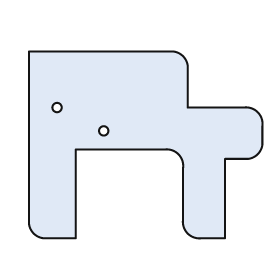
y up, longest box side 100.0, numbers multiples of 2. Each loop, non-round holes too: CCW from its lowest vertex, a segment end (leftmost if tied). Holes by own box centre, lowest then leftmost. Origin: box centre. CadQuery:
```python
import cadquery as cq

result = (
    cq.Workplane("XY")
    .moveTo(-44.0, -40.0)
    .lineTo(-30.0, -40.0)
    .lineTo(-30.0, -2.0)
    .lineTo(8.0, -2.0)
    .threePointArc((14.0, -4.0), (16.0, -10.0))
    .lineTo(16.0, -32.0)
    .threePointArc((18.0, -38.0), (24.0, -40.0))
    .lineTo(34.0, -40.0)
    .lineTo(34.0, -6.0)
    .lineTo(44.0, -6.0)
    .threePointArc((48.0, -4.0), (50.0, 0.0))
    .lineTo(50.0, 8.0)
    .threePointArc((48.0, 14.0), (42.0, 16.0))
    .lineTo(18.0, 16.0)
    .lineTo(18.0, 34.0)
    .threePointArc((16.0, 38.0), (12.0, 40.0))
    .lineTo(-50.0, 40.0)
    .lineTo(-50.0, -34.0)
    .threePointArc((-48.0, -38.0), (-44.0, -40.0))
    .close()
    .moveTo(-18.0, 6.0)
    .circle(2.0)
    .moveTo(-38.0, 16.0)
    .circle(2.0)
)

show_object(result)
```